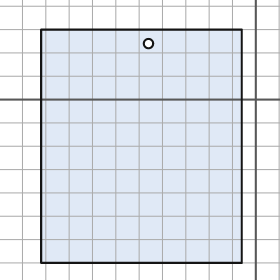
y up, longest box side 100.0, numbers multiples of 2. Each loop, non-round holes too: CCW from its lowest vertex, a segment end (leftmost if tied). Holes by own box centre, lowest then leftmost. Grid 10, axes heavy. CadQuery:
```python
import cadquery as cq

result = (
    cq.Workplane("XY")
    .moveTo(-92.0, -70.0)
    .lineTo(-6.0, -70.0)
    .lineTo(-6.0, 30.0)
    .lineTo(-92.0, 30.0)
    .close()
    .moveTo(-46.0, 24.0)
    .circle(2.0)
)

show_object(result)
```